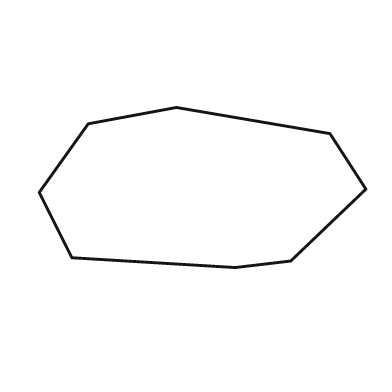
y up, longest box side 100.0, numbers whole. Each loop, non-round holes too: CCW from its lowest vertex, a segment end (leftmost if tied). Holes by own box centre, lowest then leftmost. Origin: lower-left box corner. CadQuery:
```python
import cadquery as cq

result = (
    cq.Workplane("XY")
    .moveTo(60.0, 0.0)
    .lineTo(77.0, 2.0)
    .lineTo(100.0, 24.0)
    .lineTo(89.0, 41.0)
    .lineTo(42.0, 49.0)
    .lineTo(15.0, 44.0)
    .lineTo(0.0, 23.0)
    .lineTo(10.0, 3.0)
    .close()
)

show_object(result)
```